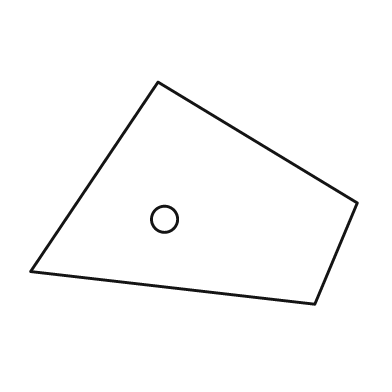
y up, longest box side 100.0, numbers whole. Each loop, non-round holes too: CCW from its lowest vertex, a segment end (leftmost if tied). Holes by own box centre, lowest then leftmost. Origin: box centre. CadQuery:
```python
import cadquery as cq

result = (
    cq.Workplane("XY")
    .moveTo(37.0, -34.0)
    .lineTo(50.0, -3.0)
    .lineTo(-11.0, 34.0)
    .lineTo(-50.0, -24.0)
    .close()
    .moveTo(-9.0, -8.0)
    .circle(4.0)
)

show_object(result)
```